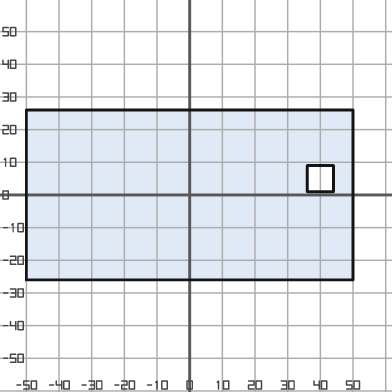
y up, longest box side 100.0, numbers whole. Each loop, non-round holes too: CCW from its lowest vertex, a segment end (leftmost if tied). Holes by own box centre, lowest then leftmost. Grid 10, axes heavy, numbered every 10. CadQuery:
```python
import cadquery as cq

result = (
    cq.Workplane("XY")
    .moveTo(-50.0, -26.0)
    .lineTo(50.0, -26.0)
    .lineTo(50.0, 26.0)
    .lineTo(-50.0, 26.0)
    .close()
    .moveTo(36.0, 1.0)
    .lineTo(44.0, 1.0)
    .lineTo(44.0, 9.0)
    .lineTo(36.0, 9.0)
    .close()
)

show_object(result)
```